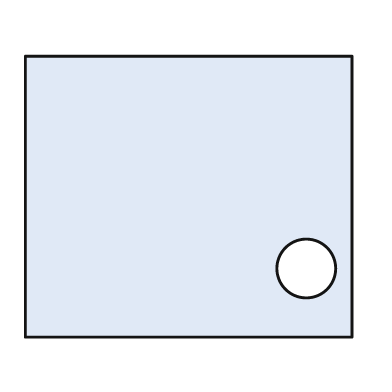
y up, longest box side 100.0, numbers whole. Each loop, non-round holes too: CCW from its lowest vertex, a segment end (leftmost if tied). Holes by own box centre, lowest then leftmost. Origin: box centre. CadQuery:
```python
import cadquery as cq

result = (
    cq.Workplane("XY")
    .moveTo(-50.0, -43.0)
    .lineTo(50.0, -43.0)
    .lineTo(50.0, 43.0)
    .lineTo(-50.0, 43.0)
    .close()
    .moveTo(36.0, -22.0)
    .circle(9.0)
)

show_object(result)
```